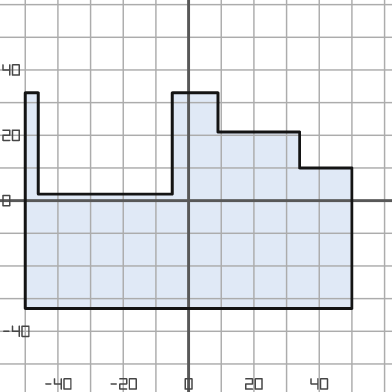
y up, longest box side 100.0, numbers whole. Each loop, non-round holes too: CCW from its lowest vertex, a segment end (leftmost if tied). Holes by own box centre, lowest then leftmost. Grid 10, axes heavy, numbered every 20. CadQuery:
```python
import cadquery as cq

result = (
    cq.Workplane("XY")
    .moveTo(-50.0, -33.0)
    .lineTo(50.0, -33.0)
    .lineTo(50.0, 10.0)
    .lineTo(34.0, 10.0)
    .lineTo(34.0, 21.0)
    .lineTo(9.0, 21.0)
    .lineTo(9.0, 33.0)
    .lineTo(-5.0, 33.0)
    .lineTo(-5.0, 2.0)
    .lineTo(-46.0, 2.0)
    .lineTo(-46.0, 33.0)
    .lineTo(-50.0, 33.0)
    .close()
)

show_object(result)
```